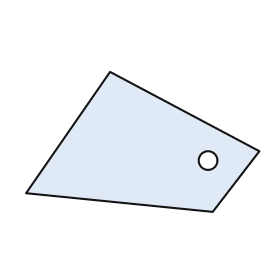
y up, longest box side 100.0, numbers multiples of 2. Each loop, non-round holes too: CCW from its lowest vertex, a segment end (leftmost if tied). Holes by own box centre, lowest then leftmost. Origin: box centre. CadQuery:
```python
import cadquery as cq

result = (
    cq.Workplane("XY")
    .moveTo(30.0, -30.0)
    .lineTo(50.0, -4.0)
    .lineTo(-14.0, 30.0)
    .lineTo(-50.0, -22.0)
    .close()
    .moveTo(28.0, -8.0)
    .circle(4.0)
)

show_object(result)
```